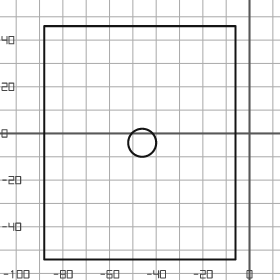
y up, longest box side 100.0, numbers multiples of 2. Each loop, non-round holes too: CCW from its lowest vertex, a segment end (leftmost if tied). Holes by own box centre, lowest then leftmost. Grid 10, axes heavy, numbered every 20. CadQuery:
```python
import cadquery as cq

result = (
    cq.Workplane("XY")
    .moveTo(-88.0, -54.0)
    .lineTo(-6.0, -54.0)
    .lineTo(-6.0, 46.0)
    .lineTo(-88.0, 46.0)
    .close()
    .moveTo(-46.0, -4.0)
    .circle(6.0)
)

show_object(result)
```